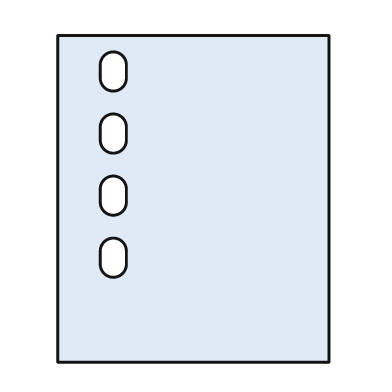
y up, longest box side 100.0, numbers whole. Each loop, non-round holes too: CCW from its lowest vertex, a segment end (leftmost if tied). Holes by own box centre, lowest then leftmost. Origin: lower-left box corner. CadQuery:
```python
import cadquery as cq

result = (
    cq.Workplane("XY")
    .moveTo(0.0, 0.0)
    .lineTo(83.0, 0.0)
    .lineTo(83.0, 100.0)
    .lineTo(0.0, 100.0)
    .close()
    .moveTo(13.0, 30.0)
    .threePointArc((17.0, 26.0), (21.0, 30.0))
    .lineTo(21.0, 34.0)
    .threePointArc((17.0, 38.0), (13.0, 34.0))
    .close()
    .moveTo(13.0, 49.0)
    .threePointArc((17.0, 45.0), (21.0, 49.0))
    .lineTo(21.0, 53.0)
    .threePointArc((17.0, 57.0), (13.0, 53.0))
    .close()
    .moveTo(13.0, 68.0)
    .threePointArc((17.0, 64.0), (21.0, 68.0))
    .lineTo(21.0, 72.0)
    .threePointArc((17.0, 76.0), (13.0, 72.0))
    .close()
    .moveTo(13.0, 87.0)
    .threePointArc((17.0, 83.0), (21.0, 87.0))
    .lineTo(21.0, 91.0)
    .threePointArc((17.0, 95.0), (13.0, 91.0))
    .close()
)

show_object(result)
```